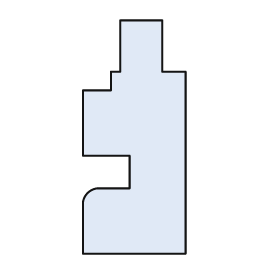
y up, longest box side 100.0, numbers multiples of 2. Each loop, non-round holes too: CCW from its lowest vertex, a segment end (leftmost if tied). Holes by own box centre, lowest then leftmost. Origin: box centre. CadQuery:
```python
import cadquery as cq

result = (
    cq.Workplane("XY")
    .moveTo(-22.0, -50.0)
    .lineTo(22.0, -50.0)
    .lineTo(22.0, 28.0)
    .lineTo(12.0, 28.0)
    .lineTo(12.0, 50.0)
    .lineTo(-6.0, 50.0)
    .lineTo(-6.0, 28.0)
    .lineTo(-10.0, 28.0)
    .lineTo(-10.0, 20.0)
    .lineTo(-22.0, 20.0)
    .lineTo(-22.0, -8.0)
    .lineTo(-2.0, -8.0)
    .lineTo(-2.0, -22.0)
    .lineTo(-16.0, -22.0)
    .threePointArc((-20.0, -24.0), (-22.0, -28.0))
    .close()
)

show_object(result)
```